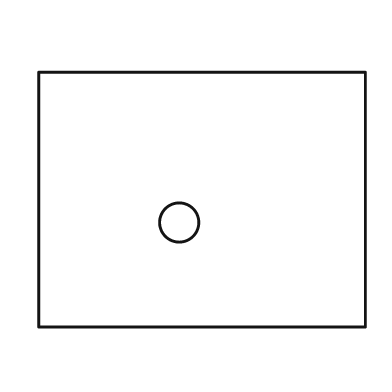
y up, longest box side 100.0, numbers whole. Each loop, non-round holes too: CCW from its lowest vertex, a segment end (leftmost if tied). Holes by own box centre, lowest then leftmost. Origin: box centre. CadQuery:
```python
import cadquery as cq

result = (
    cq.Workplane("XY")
    .moveTo(-50.0, -39.0)
    .lineTo(50.0, -39.0)
    .lineTo(50.0, 39.0)
    .lineTo(-50.0, 39.0)
    .close()
    .moveTo(-7.0, -7.0)
    .circle(6.0)
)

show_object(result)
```